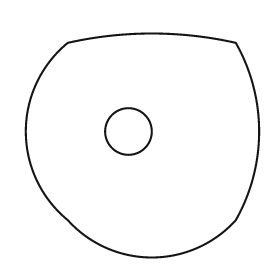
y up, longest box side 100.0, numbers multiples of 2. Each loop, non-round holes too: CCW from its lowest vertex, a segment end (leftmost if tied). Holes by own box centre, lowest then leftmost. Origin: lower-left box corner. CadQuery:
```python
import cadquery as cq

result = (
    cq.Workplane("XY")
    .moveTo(18.0, 16.0)
    .threePointArc((54.0, 0.0), (90.0, 16.0))
    .threePointArc((100.0, 54.0), (90.0, 92.0))
    .threePointArc((54.0, 96.0), (18.0, 92.0))
    .threePointArc((0.0, 54.0), (18.0, 16.0))
    .close()
    .moveTo(44.0, 54.0)
    .circle(10.0)
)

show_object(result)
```